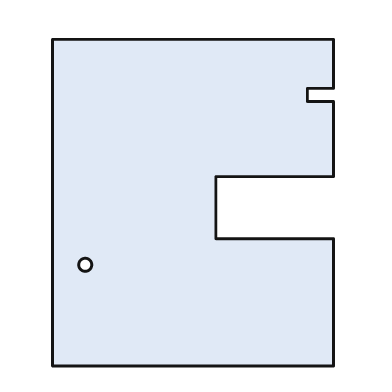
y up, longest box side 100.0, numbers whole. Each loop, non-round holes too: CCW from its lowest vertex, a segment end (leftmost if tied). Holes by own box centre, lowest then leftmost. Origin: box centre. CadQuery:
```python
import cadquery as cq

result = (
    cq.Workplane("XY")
    .moveTo(-43.0, -50.0)
    .lineTo(43.0, -50.0)
    .lineTo(43.0, -11.0)
    .lineTo(7.0, -11.0)
    .lineTo(7.0, 8.0)
    .lineTo(43.0, 8.0)
    .lineTo(43.0, 31.0)
    .lineTo(35.0, 31.0)
    .lineTo(35.0, 35.0)
    .lineTo(43.0, 35.0)
    .lineTo(43.0, 50.0)
    .lineTo(-43.0, 50.0)
    .close()
    .moveTo(-33.0, -19.0)
    .circle(2.0)
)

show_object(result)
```